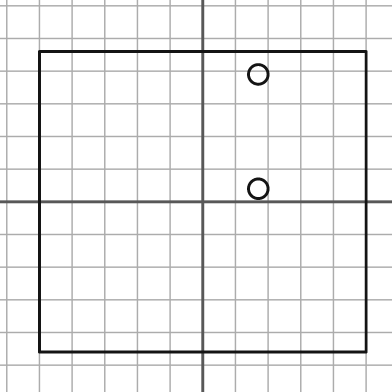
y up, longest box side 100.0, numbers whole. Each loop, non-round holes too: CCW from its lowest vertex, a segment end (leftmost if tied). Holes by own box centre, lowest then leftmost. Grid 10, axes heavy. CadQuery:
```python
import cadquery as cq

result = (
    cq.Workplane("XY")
    .moveTo(-50.0, -46.0)
    .lineTo(50.0, -46.0)
    .lineTo(50.0, 46.0)
    .lineTo(-50.0, 46.0)
    .close()
    .moveTo(17.0, 4.0)
    .circle(3.0)
    .moveTo(17.0, 39.0)
    .circle(3.0)
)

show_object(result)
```